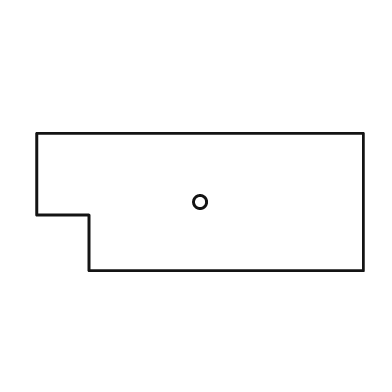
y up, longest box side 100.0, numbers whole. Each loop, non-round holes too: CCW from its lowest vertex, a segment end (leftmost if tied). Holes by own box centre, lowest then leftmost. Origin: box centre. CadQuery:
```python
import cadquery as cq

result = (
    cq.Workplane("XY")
    .moveTo(-34.0, -21.0)
    .lineTo(50.0, -21.0)
    .lineTo(50.0, 21.0)
    .lineTo(-50.0, 21.0)
    .lineTo(-50.0, -4.0)
    .lineTo(-34.0, -4.0)
    .close()
    .moveTo(0.0, 0.0)
    .circle(2.0)
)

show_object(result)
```